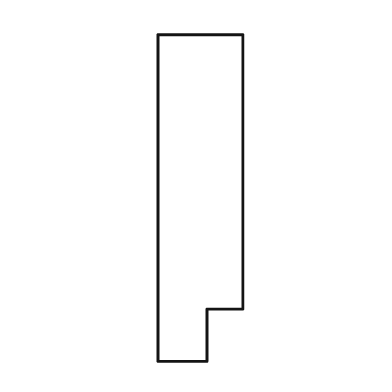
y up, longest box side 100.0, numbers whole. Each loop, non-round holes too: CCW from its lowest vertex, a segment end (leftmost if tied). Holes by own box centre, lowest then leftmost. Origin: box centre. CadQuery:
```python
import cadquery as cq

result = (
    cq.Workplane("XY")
    .moveTo(-13.0, -50.0)
    .lineTo(2.0, -50.0)
    .lineTo(2.0, -34.0)
    .lineTo(13.0, -34.0)
    .lineTo(13.0, 50.0)
    .lineTo(-13.0, 50.0)
    .close()
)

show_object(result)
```